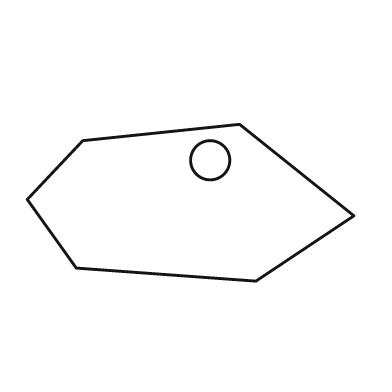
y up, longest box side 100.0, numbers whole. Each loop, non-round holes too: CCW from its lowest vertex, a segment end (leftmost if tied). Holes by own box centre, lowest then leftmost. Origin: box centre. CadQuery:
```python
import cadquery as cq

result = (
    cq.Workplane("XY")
    .moveTo(20.0, -24.0)
    .lineTo(50.0, -4.0)
    .lineTo(15.0, 24.0)
    .lineTo(-33.0, 19.0)
    .lineTo(-50.0, 1.0)
    .lineTo(-35.0, -20.0)
    .close()
    .moveTo(6.0, 13.0)
    .circle(6.0)
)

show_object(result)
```